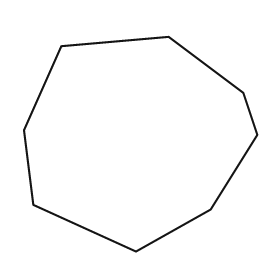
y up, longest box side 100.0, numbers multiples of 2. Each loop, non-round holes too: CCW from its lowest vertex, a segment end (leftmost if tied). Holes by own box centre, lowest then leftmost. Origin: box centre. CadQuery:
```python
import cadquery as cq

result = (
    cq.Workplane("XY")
    .moveTo(-2.0, -46.0)
    .lineTo(30.0, -28.0)
    .lineTo(50.0, 4.0)
    .lineTo(44.0, 22.0)
    .lineTo(12.0, 46.0)
    .lineTo(-34.0, 42.0)
    .lineTo(-50.0, 6.0)
    .lineTo(-46.0, -26.0)
    .close()
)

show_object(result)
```